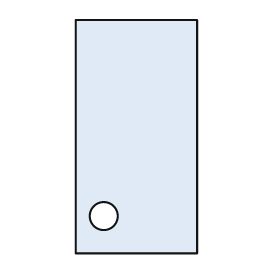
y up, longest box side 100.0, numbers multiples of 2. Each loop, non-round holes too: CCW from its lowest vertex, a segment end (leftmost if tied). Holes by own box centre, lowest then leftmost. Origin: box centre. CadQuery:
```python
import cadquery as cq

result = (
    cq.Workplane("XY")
    .moveTo(-26.0, -50.0)
    .lineTo(26.0, -50.0)
    .lineTo(26.0, 50.0)
    .lineTo(-26.0, 50.0)
    .close()
    .moveTo(-14.0, -34.0)
    .circle(6.0)
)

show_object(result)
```